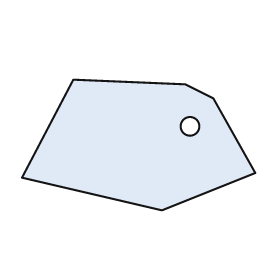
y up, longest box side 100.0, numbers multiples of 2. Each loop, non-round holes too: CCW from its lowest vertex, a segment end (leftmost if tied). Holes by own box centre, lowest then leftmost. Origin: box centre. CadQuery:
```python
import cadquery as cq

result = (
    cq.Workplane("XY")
    .moveTo(10.0, -28.0)
    .lineTo(50.0, -12.0)
    .lineTo(32.0, 20.0)
    .lineTo(20.0, 26.0)
    .lineTo(-28.0, 28.0)
    .lineTo(-50.0, -14.0)
    .close()
    .moveTo(22.0, 8.0)
    .circle(4.0)
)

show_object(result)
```